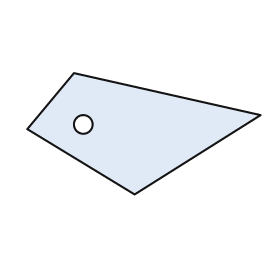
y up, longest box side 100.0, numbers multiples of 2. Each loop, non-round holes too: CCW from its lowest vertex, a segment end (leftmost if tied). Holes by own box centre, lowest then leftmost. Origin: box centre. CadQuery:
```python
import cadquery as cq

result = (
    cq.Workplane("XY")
    .moveTo(-4.0, -26.0)
    .lineTo(50.0, 8.0)
    .lineTo(-30.0, 26.0)
    .lineTo(-50.0, 2.0)
    .close()
    .moveTo(-26.0, 4.0)
    .circle(4.0)
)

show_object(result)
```